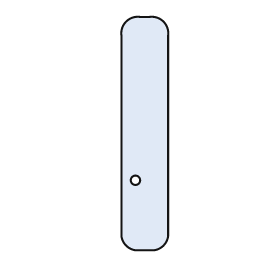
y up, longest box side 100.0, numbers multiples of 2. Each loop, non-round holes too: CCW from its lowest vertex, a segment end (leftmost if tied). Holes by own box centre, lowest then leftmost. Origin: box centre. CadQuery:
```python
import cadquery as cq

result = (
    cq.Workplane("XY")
    .moveTo(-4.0, -50.0)
    .lineTo(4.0, -50.0)
    .threePointArc((8.0, -48.0), (10.0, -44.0))
    .lineTo(10.0, 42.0)
    .threePointArc((8.0, 48.0), (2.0, 50.0))
    .lineTo(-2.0, 50.0)
    .threePointArc((-8.0, 48.0), (-10.0, 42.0))
    .lineTo(-10.0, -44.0)
    .threePointArc((-8.0, -48.0), (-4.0, -50.0))
    .close()
    .moveTo(-4.0, -20.0)
    .circle(2.0)
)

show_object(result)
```